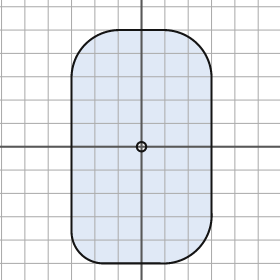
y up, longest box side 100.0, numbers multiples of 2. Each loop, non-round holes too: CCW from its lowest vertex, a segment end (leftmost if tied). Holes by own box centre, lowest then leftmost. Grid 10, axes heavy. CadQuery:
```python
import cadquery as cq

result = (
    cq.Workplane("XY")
    .moveTo(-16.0, -50.0)
    .lineTo(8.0, -50.0)
    .threePointArc((24.0, -44.0), (30.0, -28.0))
    .lineTo(30.0, 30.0)
    .threePointArc((24.0, 44.0), (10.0, 50.0))
    .lineTo(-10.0, 50.0)
    .threePointArc((-24.0, 44.0), (-30.0, 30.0))
    .lineTo(-30.0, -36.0)
    .threePointArc((-26.0, -46.0), (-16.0, -50.0))
    .close()
    .moveTo(0.0, 0.0)
    .circle(2.0)
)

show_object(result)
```